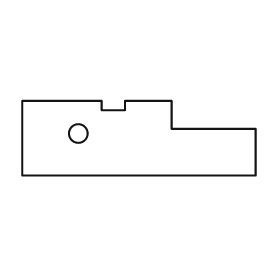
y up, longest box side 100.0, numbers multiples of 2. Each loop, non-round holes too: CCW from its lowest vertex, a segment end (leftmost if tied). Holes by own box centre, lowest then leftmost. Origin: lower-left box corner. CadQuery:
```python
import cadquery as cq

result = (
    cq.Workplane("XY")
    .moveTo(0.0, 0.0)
    .lineTo(100.0, 0.0)
    .lineTo(100.0, 20.0)
    .lineTo(64.0, 20.0)
    .lineTo(64.0, 32.0)
    .lineTo(44.0, 32.0)
    .lineTo(44.0, 28.0)
    .lineTo(34.0, 28.0)
    .lineTo(34.0, 32.0)
    .lineTo(0.0, 32.0)
    .close()
    .moveTo(24.0, 18.0)
    .circle(4.0)
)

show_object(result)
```